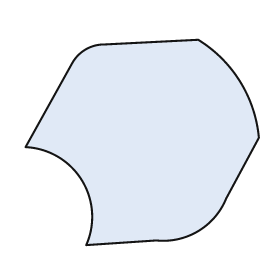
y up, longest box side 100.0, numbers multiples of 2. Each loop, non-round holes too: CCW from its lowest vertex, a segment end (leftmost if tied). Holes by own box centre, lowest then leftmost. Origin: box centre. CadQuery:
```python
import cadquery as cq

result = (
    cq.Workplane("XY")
    .moveTo(-24.0, -44.0)
    .lineTo(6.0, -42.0)
    .threePointArc((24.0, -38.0), (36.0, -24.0))
    .lineTo(50.0, 2.0)
    .threePointArc((42.0, 26.0), (24.0, 44.0))
    .lineTo(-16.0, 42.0)
    .threePointArc((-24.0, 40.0), (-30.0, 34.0))
    .lineTo(-50.0, -2.0)
    .threePointArc((-26.0, -16.0), (-24.0, -44.0))
    .close()
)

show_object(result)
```